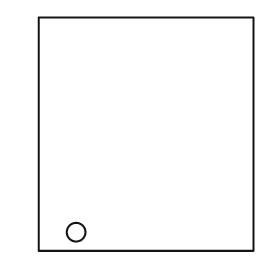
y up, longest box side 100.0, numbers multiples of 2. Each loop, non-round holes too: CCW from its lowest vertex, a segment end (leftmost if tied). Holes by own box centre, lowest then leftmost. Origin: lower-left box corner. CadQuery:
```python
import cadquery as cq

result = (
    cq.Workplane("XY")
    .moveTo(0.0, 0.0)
    .lineTo(92.0, 0.0)
    .lineTo(92.0, 100.0)
    .lineTo(0.0, 100.0)
    .close()
    .moveTo(16.0, 8.0)
    .circle(4.0)
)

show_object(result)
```